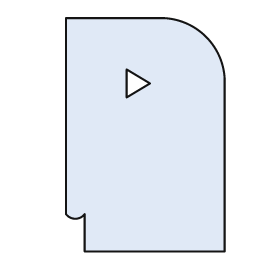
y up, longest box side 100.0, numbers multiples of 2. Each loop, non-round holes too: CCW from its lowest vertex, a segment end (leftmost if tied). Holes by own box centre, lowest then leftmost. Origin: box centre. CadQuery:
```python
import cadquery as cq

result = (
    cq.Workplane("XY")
    .moveTo(-26.0, -50.0)
    .lineTo(34.0, -50.0)
    .lineTo(34.0, 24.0)
    .threePointArc((26.0, 42.0), (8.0, 50.0))
    .lineTo(-34.0, 50.0)
    .lineTo(-34.0, -34.0)
    .threePointArc((-30.0, -36.0), (-26.0, -34.0))
    .close()
    .moveTo(-8.0, 16.0)
    .lineTo(2.0, 22.0)
    .lineTo(-8.0, 28.0)
    .close()
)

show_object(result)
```